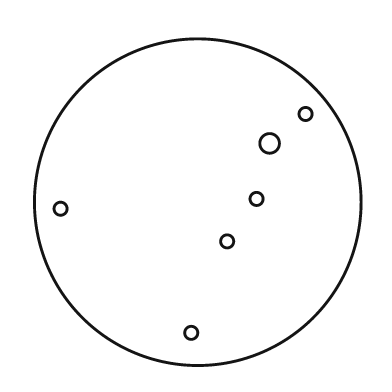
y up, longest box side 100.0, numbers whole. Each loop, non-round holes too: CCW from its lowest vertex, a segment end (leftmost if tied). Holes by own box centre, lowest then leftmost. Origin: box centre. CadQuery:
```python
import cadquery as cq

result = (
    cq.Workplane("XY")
    .moveTo(0.0, 0.0)
    .circle(50.0)
    .moveTo(-2.0, -40.0)
    .circle(2.0)
    .moveTo(9.0, -12.0)
    .circle(2.0)
    .moveTo(-42.0, -2.0)
    .circle(2.0)
    .moveTo(18.0, 1.0)
    .circle(2.0)
    .moveTo(22.0, 18.0)
    .circle(3.0)
    .moveTo(33.0, 27.0)
    .circle(2.0)
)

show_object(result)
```